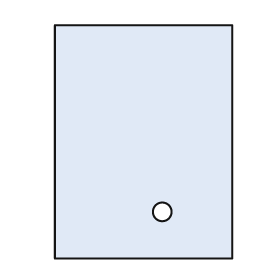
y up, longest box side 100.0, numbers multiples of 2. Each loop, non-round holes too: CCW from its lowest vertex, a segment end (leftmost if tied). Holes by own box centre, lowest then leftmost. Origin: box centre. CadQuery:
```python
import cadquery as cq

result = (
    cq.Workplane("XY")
    .moveTo(-38.0, -50.0)
    .lineTo(38.0, -50.0)
    .lineTo(38.0, 50.0)
    .lineTo(-38.0, 50.0)
    .close()
    .moveTo(8.0, -30.0)
    .circle(4.0)
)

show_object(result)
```